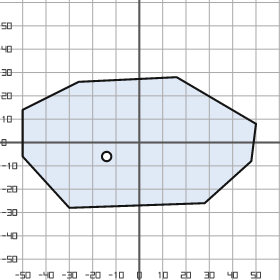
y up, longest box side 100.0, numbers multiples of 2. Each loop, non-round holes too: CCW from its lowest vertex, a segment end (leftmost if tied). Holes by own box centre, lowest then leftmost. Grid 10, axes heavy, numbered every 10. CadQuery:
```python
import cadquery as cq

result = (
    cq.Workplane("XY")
    .moveTo(-30.0, -28.0)
    .lineTo(28.0, -26.0)
    .lineTo(48.0, -8.0)
    .lineTo(50.0, 8.0)
    .lineTo(16.0, 28.0)
    .lineTo(-26.0, 26.0)
    .lineTo(-50.0, 14.0)
    .lineTo(-50.0, -6.0)
    .close()
    .moveTo(-14.0, -6.0)
    .circle(2.0)
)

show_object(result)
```